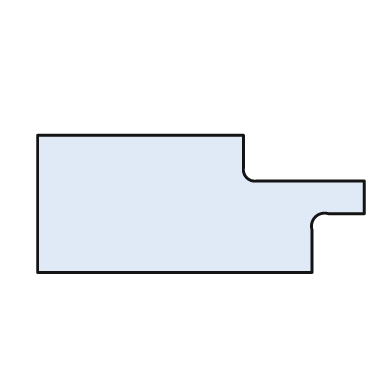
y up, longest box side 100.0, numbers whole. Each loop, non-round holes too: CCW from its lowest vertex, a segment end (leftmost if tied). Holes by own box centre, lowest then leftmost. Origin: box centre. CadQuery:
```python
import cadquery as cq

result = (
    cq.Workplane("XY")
    .moveTo(-50.0, -21.0)
    .lineTo(34.0, -21.0)
    .lineTo(34.0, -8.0)
    .threePointArc((35.0, -4.0), (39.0, -3.0))
    .lineTo(50.0, -3.0)
    .lineTo(50.0, 7.0)
    .lineTo(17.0, 7.0)
    .threePointArc((14.0, 8.0), (13.0, 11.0))
    .lineTo(13.0, 21.0)
    .lineTo(-50.0, 21.0)
    .close()
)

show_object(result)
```